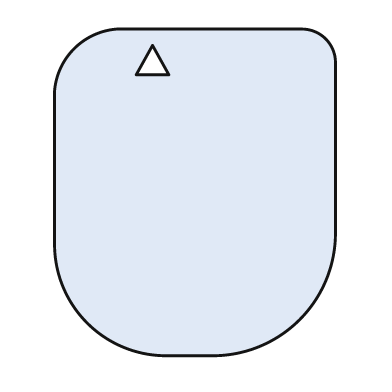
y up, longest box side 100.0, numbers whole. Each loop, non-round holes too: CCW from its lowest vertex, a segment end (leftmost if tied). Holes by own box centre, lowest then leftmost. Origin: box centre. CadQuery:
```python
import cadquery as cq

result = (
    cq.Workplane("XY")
    .moveTo(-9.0, -50.0)
    .lineTo(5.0, -50.0)
    .threePointArc((32.0, -39.0), (43.0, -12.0))
    .lineTo(43.0, 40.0)
    .threePointArc((40.0, 47.0), (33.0, 50.0))
    .lineTo(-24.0, 50.0)
    .threePointArc((-37.0, 44.0), (-43.0, 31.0))
    .lineTo(-43.0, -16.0)
    .threePointArc((-33.0, -40.0), (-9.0, -50.0))
    .close()
    .moveTo(-18.0, 36.0)
    .lineTo(-8.0, 36.0)
    .lineTo(-13.0, 45.0)
    .close()
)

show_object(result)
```